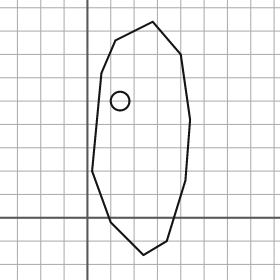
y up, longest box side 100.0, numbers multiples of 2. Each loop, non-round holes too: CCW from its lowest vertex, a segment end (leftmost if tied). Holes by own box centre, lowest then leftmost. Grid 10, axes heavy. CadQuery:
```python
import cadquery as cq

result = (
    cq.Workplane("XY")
    .moveTo(24.0, -16.0)
    .lineTo(34.0, -10.0)
    .lineTo(42.0, 16.0)
    .lineTo(44.0, 42.0)
    .lineTo(40.0, 70.0)
    .lineTo(28.0, 84.0)
    .lineTo(12.0, 76.0)
    .lineTo(6.0, 62.0)
    .lineTo(2.0, 20.0)
    .lineTo(10.0, -2.0)
    .close()
    .moveTo(14.0, 50.0)
    .circle(4.0)
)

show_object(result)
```